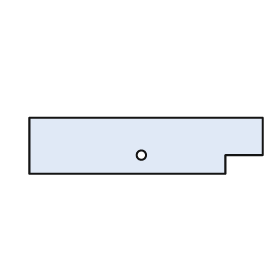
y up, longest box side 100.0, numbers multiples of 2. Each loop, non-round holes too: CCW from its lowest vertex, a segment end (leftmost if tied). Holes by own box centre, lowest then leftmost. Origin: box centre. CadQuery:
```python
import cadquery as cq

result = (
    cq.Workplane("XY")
    .moveTo(-50.0, -12.0)
    .lineTo(34.0, -12.0)
    .lineTo(34.0, -4.0)
    .lineTo(50.0, -4.0)
    .lineTo(50.0, 12.0)
    .lineTo(-50.0, 12.0)
    .close()
    .moveTo(-2.0, -4.0)
    .circle(2.0)
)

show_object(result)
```